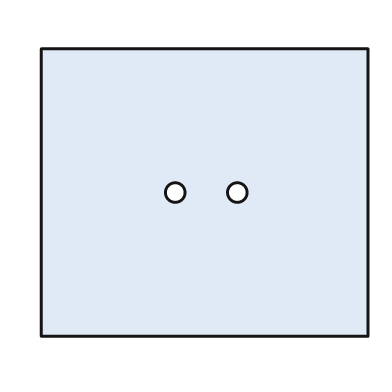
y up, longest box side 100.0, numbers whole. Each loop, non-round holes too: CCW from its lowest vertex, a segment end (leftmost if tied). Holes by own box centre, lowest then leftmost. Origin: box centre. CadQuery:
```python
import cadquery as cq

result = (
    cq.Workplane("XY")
    .moveTo(-50.0, -44.0)
    .lineTo(50.0, -44.0)
    .lineTo(50.0, 44.0)
    .lineTo(-50.0, 44.0)
    .close()
    .moveTo(-9.0, 0.0)
    .circle(3.0)
    .moveTo(10.0, 0.0)
    .circle(3.0)
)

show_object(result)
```